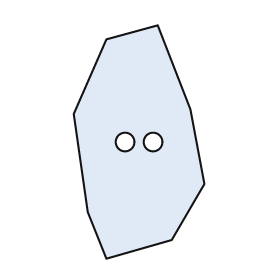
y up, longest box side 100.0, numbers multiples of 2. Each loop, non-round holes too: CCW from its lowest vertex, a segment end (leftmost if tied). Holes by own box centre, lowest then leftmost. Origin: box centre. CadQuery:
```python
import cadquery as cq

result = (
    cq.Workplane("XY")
    .moveTo(-14.0, -50.0)
    .lineTo(14.0, -42.0)
    .lineTo(28.0, -18.0)
    .lineTo(22.0, 14.0)
    .lineTo(8.0, 50.0)
    .lineTo(-14.0, 44.0)
    .lineTo(-28.0, 12.0)
    .lineTo(-22.0, -30.0)
    .close()
    .moveTo(-6.0, 0.0)
    .circle(4.0)
    .moveTo(6.0, 0.0)
    .circle(4.0)
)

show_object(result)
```